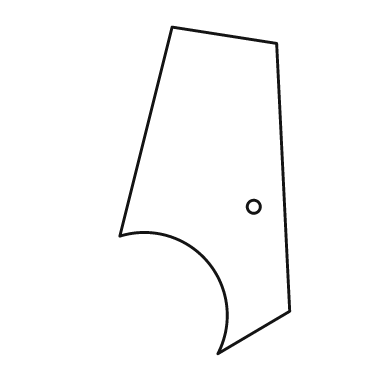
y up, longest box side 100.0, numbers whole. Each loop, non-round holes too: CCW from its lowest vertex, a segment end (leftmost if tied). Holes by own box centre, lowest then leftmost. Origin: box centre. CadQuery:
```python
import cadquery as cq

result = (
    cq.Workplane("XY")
    .moveTo(4.0, -50.0)
    .lineTo(26.0, -37.0)
    .lineTo(22.0, 45.0)
    .lineTo(-10.0, 50.0)
    .lineTo(-26.0, -14.0)
    .threePointArc((1.0, -22.0), (4.0, -50.0))
    .close()
    .moveTo(15.0, -5.0)
    .circle(2.0)
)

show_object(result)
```